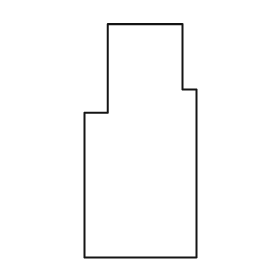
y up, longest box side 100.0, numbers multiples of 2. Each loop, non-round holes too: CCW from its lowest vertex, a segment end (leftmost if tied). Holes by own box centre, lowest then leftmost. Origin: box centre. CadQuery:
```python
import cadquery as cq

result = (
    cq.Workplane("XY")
    .moveTo(-24.0, -50.0)
    .lineTo(24.0, -50.0)
    .lineTo(24.0, 22.0)
    .lineTo(18.0, 22.0)
    .lineTo(18.0, 50.0)
    .lineTo(-14.0, 50.0)
    .lineTo(-14.0, 12.0)
    .lineTo(-24.0, 12.0)
    .close()
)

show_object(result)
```